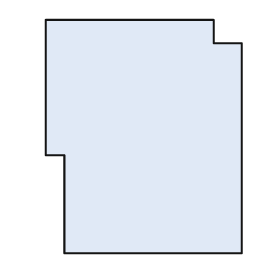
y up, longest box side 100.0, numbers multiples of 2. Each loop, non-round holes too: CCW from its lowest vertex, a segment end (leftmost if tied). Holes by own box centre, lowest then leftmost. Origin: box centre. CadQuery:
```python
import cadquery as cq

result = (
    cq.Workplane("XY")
    .moveTo(-34.0, -50.0)
    .lineTo(42.0, -50.0)
    .lineTo(42.0, 40.0)
    .lineTo(30.0, 40.0)
    .lineTo(30.0, 50.0)
    .lineTo(-42.0, 50.0)
    .lineTo(-42.0, -8.0)
    .lineTo(-34.0, -8.0)
    .close()
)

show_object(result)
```